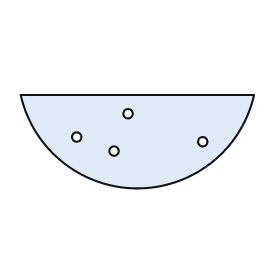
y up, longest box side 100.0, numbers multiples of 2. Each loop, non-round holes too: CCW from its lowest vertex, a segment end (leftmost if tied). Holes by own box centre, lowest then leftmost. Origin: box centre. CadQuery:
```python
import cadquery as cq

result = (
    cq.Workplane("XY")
    .moveTo(-50.0, 20.0)
    .threePointArc((0.0, -20.0), (50.0, 20.0))
    .close()
    .moveTo(-10.0, -4.0)
    .circle(2.0)
    .moveTo(28.0, 0.0)
    .circle(2.0)
    .moveTo(-26.0, 2.0)
    .circle(2.0)
    .moveTo(-4.0, 12.0)
    .circle(2.0)
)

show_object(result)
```